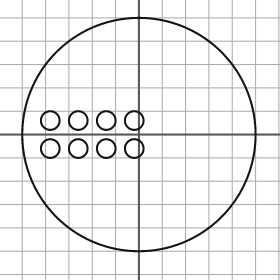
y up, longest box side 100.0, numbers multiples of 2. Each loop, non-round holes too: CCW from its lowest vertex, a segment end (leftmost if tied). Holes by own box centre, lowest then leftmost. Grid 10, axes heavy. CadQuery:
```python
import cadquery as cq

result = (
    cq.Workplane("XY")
    .moveTo(0.0, 0.0)
    .circle(50.0)
    .moveTo(-38.0, -6.0)
    .circle(4.0)
    .moveTo(-26.0, -6.0)
    .circle(4.0)
    .moveTo(-14.0, -6.0)
    .circle(4.0)
    .moveTo(-2.0, -6.0)
    .circle(4.0)
    .moveTo(-38.0, 6.0)
    .circle(4.0)
    .moveTo(-26.0, 6.0)
    .circle(4.0)
    .moveTo(-14.0, 6.0)
    .circle(4.0)
    .moveTo(-2.0, 6.0)
    .circle(4.0)
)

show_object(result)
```